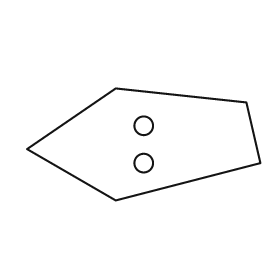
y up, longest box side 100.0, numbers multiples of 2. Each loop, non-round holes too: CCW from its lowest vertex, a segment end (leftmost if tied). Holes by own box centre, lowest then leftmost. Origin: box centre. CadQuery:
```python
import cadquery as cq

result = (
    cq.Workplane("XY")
    .moveTo(-12.0, -24.0)
    .lineTo(50.0, -8.0)
    .lineTo(44.0, 18.0)
    .lineTo(-12.0, 24.0)
    .lineTo(-50.0, -2.0)
    .close()
    .moveTo(0.0, -8.0)
    .circle(4.0)
    .moveTo(0.0, 8.0)
    .circle(4.0)
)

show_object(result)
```